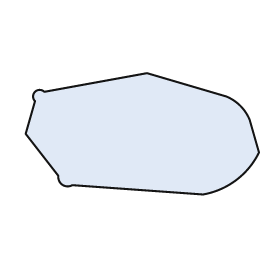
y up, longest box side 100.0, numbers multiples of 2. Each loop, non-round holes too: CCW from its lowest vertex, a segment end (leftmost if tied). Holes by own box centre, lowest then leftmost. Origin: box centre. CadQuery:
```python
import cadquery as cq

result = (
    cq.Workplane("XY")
    .moveTo(26.0, -26.0)
    .threePointArc((40.0, -20.0), (50.0, -8.0))
    .lineTo(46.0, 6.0)
    .threePointArc((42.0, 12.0), (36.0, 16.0))
    .lineTo(2.0, 26.0)
    .lineTo(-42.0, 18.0)
    .threePointArc((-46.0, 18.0), (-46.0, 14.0))
    .lineTo(-50.0, 0.0)
    .lineTo(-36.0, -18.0)
    .threePointArc((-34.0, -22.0), (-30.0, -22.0))
    .close()
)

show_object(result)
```